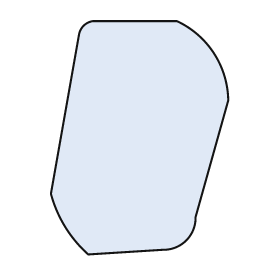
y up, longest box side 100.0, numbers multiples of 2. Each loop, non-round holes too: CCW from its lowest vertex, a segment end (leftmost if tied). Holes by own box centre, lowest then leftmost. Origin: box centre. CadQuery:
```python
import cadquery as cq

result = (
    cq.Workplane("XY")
    .moveTo(-22.0, -50.0)
    .lineTo(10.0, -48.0)
    .threePointArc((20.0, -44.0), (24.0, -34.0))
    .lineTo(38.0, 16.0)
    .threePointArc((32.0, 36.0), (16.0, 50.0))
    .lineTo(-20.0, 50.0)
    .threePointArc((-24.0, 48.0), (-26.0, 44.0))
    .lineTo(-38.0, -24.0)
    .threePointArc((-32.0, -38.0), (-22.0, -50.0))
    .close()
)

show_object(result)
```